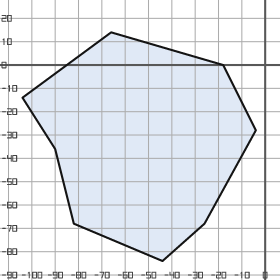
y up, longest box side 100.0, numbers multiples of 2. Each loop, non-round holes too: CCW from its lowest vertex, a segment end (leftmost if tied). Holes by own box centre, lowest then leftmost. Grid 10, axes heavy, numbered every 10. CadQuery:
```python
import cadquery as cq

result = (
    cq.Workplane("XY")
    .moveTo(-44.0, -84.0)
    .lineTo(-26.0, -68.0)
    .lineTo(-4.0, -28.0)
    .lineTo(-18.0, 0.0)
    .lineTo(-66.0, 14.0)
    .lineTo(-104.0, -14.0)
    .lineTo(-90.0, -36.0)
    .lineTo(-82.0, -68.0)
    .close()
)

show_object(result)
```